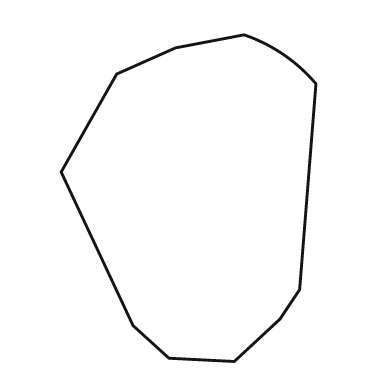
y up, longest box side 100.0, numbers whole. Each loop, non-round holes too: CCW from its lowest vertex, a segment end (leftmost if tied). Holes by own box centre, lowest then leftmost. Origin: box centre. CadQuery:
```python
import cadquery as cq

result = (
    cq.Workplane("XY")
    .moveTo(14.0, -50.0)
    .lineTo(28.0, -37.0)
    .lineTo(34.0, -28.0)
    .lineTo(39.0, 35.0)
    .threePointArc((29.0, 44.0), (17.0, 50.0))
    .lineTo(-4.0, 46.0)
    .lineTo(-22.0, 38.0)
    .lineTo(-39.0, 8.0)
    .lineTo(-17.0, -39.0)
    .lineTo(-6.0, -49.0)
    .close()
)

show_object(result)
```